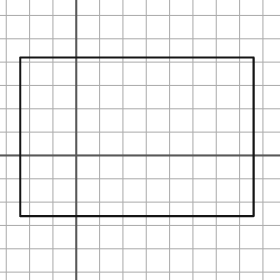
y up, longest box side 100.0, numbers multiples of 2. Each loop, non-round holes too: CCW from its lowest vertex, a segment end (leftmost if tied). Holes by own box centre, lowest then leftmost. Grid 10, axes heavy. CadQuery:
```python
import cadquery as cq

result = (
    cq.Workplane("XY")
    .moveTo(-24.0, -26.0)
    .lineTo(76.0, -26.0)
    .lineTo(76.0, 42.0)
    .lineTo(-24.0, 42.0)
    .close()
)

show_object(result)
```